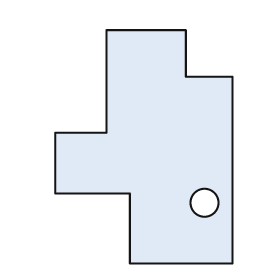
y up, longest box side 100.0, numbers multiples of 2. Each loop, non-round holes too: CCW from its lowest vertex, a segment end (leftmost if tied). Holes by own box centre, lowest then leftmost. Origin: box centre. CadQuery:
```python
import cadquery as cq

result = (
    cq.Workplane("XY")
    .moveTo(-6.0, -50.0)
    .lineTo(38.0, -50.0)
    .lineTo(38.0, 30.0)
    .lineTo(18.0, 30.0)
    .lineTo(18.0, 50.0)
    .lineTo(-16.0, 50.0)
    .lineTo(-16.0, 6.0)
    .lineTo(-38.0, 6.0)
    .lineTo(-38.0, -20.0)
    .lineTo(-6.0, -20.0)
    .close()
    .moveTo(26.0, -24.0)
    .circle(6.0)
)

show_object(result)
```